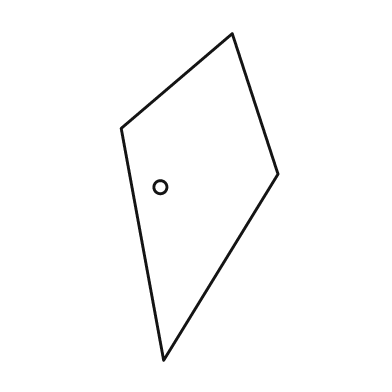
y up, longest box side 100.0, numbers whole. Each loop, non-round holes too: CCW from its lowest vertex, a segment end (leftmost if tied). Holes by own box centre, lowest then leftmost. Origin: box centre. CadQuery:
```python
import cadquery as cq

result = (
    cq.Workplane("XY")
    .moveTo(-11.0, -50.0)
    .lineTo(24.0, 7.0)
    .lineTo(10.0, 50.0)
    .lineTo(-24.0, 21.0)
    .close()
    .moveTo(-12.0, 3.0)
    .circle(2.0)
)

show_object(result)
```